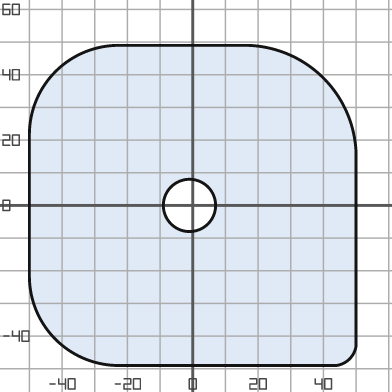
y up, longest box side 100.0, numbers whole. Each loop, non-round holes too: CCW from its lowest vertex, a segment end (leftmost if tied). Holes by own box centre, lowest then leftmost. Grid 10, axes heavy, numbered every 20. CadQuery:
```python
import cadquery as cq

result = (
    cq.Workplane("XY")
    .moveTo(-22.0, -49.0)
    .lineTo(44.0, -49.0)
    .threePointArc((48.0, -47.0), (50.0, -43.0))
    .lineTo(50.0, 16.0)
    .threePointArc((40.0, 39.0), (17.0, 49.0))
    .lineTo(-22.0, 49.0)
    .threePointArc((-42.0, 41.0), (-50.0, 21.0))
    .lineTo(-50.0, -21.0)
    .threePointArc((-42.0, -41.0), (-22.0, -49.0))
    .close()
    .moveTo(-1.0, 0.0)
    .circle(8.0)
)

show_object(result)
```